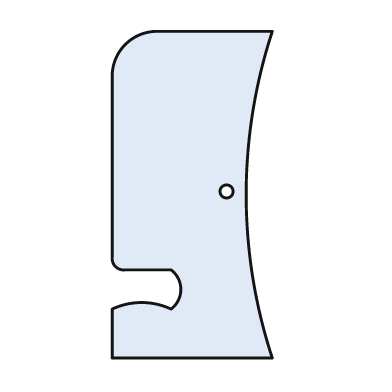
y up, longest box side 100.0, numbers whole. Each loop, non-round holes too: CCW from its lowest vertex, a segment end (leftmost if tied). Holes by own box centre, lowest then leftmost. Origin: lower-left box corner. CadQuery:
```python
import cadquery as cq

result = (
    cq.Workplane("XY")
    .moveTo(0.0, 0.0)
    .lineTo(49.0, 0.0)
    .threePointArc((41.0, 50.0), (49.0, 100.0))
    .lineTo(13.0, 100.0)
    .threePointArc((4.0, 96.0), (0.0, 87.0))
    .lineTo(0.0, 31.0)
    .threePointArc((1.0, 28.0), (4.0, 27.0))
    .lineTo(18.0, 27.0)
    .threePointArc((21.0, 21.0), (18.0, 15.0))
    .threePointArc((9.0, 17.0), (0.0, 15.0))
    .close()
    .moveTo(35.0, 51.0)
    .circle(2.0)
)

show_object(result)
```